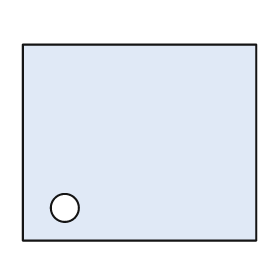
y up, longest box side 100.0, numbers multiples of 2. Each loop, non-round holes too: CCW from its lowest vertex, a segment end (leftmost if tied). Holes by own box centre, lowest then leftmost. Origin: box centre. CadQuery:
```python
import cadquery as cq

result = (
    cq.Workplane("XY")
    .moveTo(-50.0, -42.0)
    .lineTo(50.0, -42.0)
    .lineTo(50.0, 42.0)
    .lineTo(-50.0, 42.0)
    .close()
    .moveTo(-32.0, -28.0)
    .circle(6.0)
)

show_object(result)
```